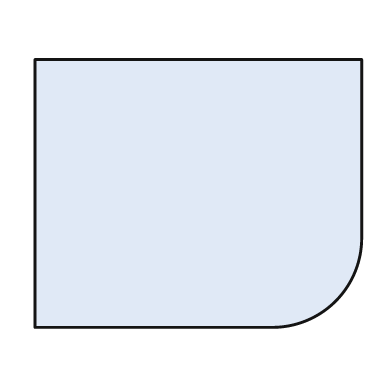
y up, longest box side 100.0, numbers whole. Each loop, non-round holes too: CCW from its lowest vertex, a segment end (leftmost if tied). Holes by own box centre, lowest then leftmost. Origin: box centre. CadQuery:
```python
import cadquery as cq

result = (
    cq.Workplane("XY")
    .moveTo(-50.0, -41.0)
    .lineTo(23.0, -41.0)
    .threePointArc((42.0, -33.0), (50.0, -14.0))
    .lineTo(50.0, 41.0)
    .lineTo(-50.0, 41.0)
    .close()
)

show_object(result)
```